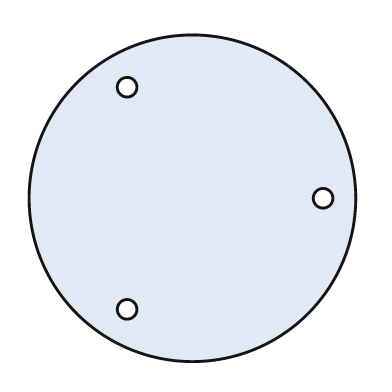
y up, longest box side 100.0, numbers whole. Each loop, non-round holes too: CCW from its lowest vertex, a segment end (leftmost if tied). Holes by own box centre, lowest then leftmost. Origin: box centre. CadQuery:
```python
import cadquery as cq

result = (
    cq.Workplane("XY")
    .moveTo(0.0, 0.0)
    .circle(50.0)
    .moveTo(-20.0, -34.0)
    .circle(3.0)
    .moveTo(40.0, 0.0)
    .circle(3.0)
    .moveTo(-20.0, 34.0)
    .circle(3.0)
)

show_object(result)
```